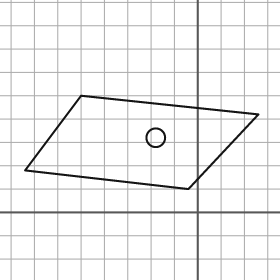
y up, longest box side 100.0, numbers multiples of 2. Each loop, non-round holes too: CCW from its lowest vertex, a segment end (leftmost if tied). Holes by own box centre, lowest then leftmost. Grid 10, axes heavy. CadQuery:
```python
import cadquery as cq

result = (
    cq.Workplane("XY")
    .moveTo(-4.0, 10.0)
    .lineTo(26.0, 42.0)
    .lineTo(-50.0, 50.0)
    .lineTo(-74.0, 18.0)
    .close()
    .moveTo(-18.0, 32.0)
    .circle(4.0)
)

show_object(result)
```